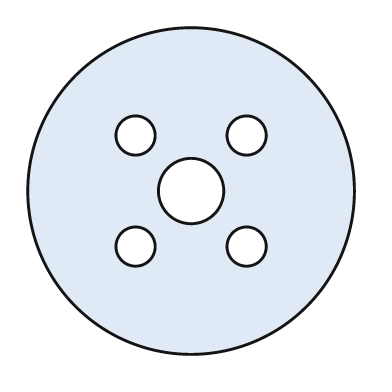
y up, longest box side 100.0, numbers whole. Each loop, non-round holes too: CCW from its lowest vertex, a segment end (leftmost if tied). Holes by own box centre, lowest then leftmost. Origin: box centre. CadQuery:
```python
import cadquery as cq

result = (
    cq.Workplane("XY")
    .moveTo(0.0, 0.0)
    .circle(50.0)
    .moveTo(-17.0, -17.0)
    .circle(6.0)
    .moveTo(17.0, -17.0)
    .circle(6.0)
    .moveTo(0.0, 0.0)
    .circle(10.0)
    .moveTo(-17.0, 17.0)
    .circle(6.0)
    .moveTo(17.0, 17.0)
    .circle(6.0)
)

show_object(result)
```